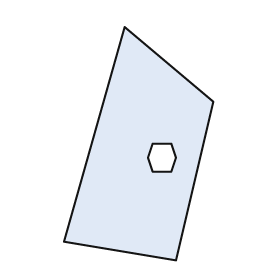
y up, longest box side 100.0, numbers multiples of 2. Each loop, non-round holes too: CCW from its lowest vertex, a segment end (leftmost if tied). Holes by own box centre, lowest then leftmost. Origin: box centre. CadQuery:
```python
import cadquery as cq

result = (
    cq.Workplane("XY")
    .moveTo(16.0, -50.0)
    .lineTo(32.0, 18.0)
    .lineTo(-6.0, 50.0)
    .lineTo(-32.0, -42.0)
    .close()
    .moveTo(6.0, -12.0)
    .lineTo(14.0, -12.0)
    .lineTo(16.0, -6.0)
    .lineTo(14.0, 0.0)
    .lineTo(6.0, 0.0)
    .lineTo(4.0, -6.0)
    .close()
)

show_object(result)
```